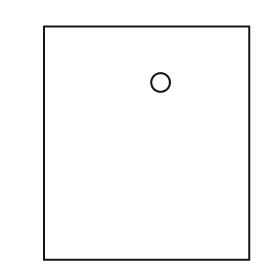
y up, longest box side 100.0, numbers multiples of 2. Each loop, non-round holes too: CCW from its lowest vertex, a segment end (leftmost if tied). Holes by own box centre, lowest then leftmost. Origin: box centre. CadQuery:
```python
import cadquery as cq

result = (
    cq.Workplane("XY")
    .moveTo(-44.0, -50.0)
    .lineTo(44.0, -50.0)
    .lineTo(44.0, 50.0)
    .lineTo(-44.0, 50.0)
    .close()
    .moveTo(6.0, 26.0)
    .circle(4.0)
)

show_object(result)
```